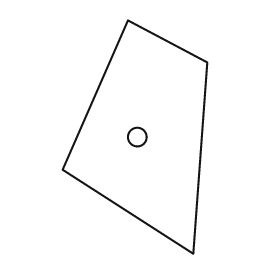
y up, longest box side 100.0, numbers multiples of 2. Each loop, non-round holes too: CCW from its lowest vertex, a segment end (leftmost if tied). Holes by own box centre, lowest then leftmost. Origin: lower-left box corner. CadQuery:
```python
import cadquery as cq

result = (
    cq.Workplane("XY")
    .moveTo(56.0, 0.0)
    .lineTo(62.0, 82.0)
    .lineTo(28.0, 100.0)
    .lineTo(0.0, 36.0)
    .close()
    .moveTo(32.0, 50.0)
    .circle(4.0)
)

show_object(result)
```